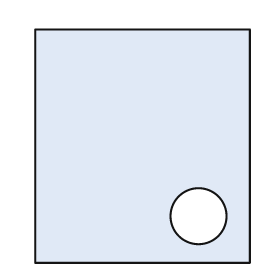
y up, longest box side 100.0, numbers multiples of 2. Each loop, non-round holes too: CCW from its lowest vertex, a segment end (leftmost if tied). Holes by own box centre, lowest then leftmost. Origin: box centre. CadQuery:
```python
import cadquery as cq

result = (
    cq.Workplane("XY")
    .moveTo(-46.0, -50.0)
    .lineTo(46.0, -50.0)
    .lineTo(46.0, 50.0)
    .lineTo(-46.0, 50.0)
    .close()
    .moveTo(24.0, -30.0)
    .circle(12.0)
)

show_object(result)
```